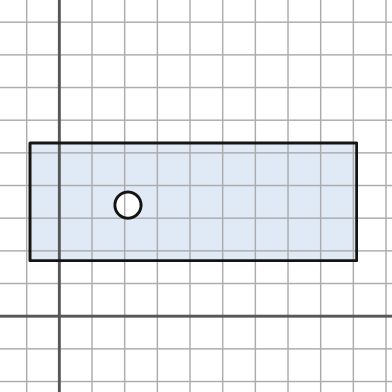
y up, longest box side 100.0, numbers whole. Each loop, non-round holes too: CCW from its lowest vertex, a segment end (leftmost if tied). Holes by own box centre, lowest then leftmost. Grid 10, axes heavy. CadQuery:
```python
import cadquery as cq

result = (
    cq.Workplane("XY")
    .moveTo(-9.0, 17.0)
    .lineTo(91.0, 17.0)
    .lineTo(91.0, 53.0)
    .lineTo(-9.0, 53.0)
    .close()
    .moveTo(21.0, 34.0)
    .circle(4.0)
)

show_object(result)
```